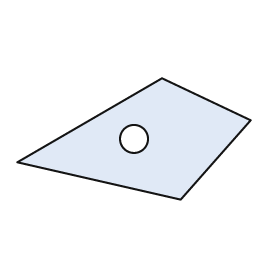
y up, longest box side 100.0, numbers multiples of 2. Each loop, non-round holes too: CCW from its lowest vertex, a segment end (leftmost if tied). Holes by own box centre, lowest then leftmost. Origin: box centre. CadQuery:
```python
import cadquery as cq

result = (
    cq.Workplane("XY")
    .moveTo(20.0, -26.0)
    .lineTo(50.0, 8.0)
    .lineTo(12.0, 26.0)
    .lineTo(-50.0, -10.0)
    .close()
    .moveTo(0.0, 0.0)
    .circle(6.0)
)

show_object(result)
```